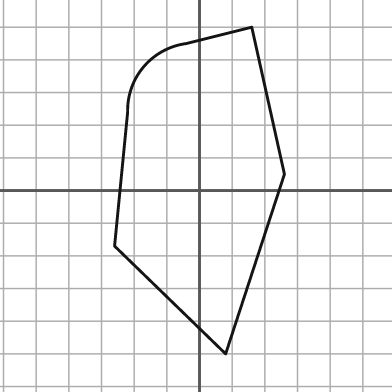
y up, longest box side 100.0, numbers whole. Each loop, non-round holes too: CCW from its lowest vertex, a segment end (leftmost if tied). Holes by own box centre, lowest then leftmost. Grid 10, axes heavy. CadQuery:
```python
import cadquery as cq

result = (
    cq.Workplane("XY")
    .moveTo(8.0, -50.0)
    .lineTo(26.0, 5.0)
    .lineTo(16.0, 50.0)
    .lineTo(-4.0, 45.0)
    .threePointArc((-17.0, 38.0), (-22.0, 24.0))
    .lineTo(-26.0, -17.0)
    .close()
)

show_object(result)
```